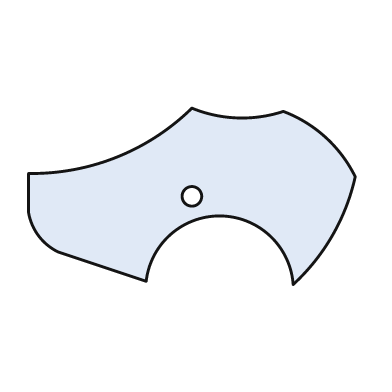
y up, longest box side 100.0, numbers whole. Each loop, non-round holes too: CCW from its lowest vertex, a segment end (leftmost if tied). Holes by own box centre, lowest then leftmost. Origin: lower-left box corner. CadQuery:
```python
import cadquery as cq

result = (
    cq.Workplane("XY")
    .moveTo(81.0, 0.0)
    .threePointArc((93.0, 15.0), (100.0, 33.0))
    .threePointArc((91.0, 45.0), (78.0, 53.0))
    .threePointArc((64.0, 51.0), (50.0, 54.0))
    .threePointArc((27.0, 39.0), (0.0, 34.0))
    .lineTo(0.0, 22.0)
    .threePointArc((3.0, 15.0), (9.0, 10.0))
    .lineTo(36.0, 1.0)
    .threePointArc((59.0, 21.0), (81.0, 0.0))
    .close()
    .moveTo(50.0, 27.0)
    .circle(3.0)
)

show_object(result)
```